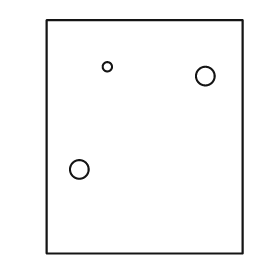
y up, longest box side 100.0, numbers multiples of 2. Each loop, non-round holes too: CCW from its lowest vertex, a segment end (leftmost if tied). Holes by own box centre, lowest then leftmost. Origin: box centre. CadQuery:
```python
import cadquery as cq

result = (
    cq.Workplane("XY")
    .moveTo(-42.0, -50.0)
    .lineTo(42.0, -50.0)
    .lineTo(42.0, 50.0)
    .lineTo(-42.0, 50.0)
    .close()
    .moveTo(-28.0, -14.0)
    .circle(4.0)
    .moveTo(26.0, 26.0)
    .circle(4.0)
    .moveTo(-16.0, 30.0)
    .circle(2.0)
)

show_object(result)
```